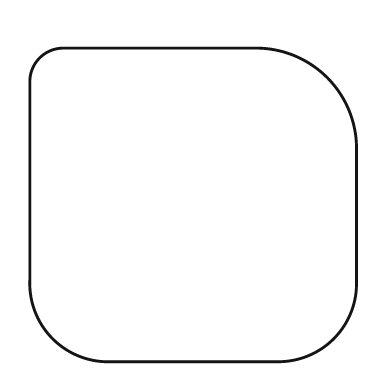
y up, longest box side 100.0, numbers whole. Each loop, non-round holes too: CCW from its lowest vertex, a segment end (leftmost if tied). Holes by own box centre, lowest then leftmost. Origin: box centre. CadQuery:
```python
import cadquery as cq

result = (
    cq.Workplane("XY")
    .moveTo(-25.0, -48.0)
    .lineTo(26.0, -48.0)
    .threePointArc((43.0, -41.0), (50.0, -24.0))
    .lineTo(50.0, 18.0)
    .threePointArc((41.0, 39.0), (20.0, 48.0))
    .lineTo(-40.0, 48.0)
    .threePointArc((-47.0, 45.0), (-50.0, 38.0))
    .lineTo(-50.0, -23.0)
    .threePointArc((-43.0, -41.0), (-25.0, -48.0))
    .close()
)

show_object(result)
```